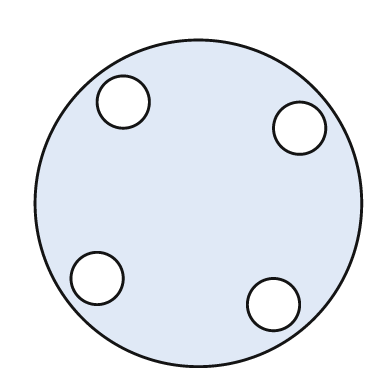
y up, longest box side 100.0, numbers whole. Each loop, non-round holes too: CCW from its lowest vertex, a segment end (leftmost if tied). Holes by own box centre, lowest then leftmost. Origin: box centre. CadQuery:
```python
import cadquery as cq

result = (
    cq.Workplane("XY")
    .moveTo(0.0, 0.0)
    .circle(50.0)
    .moveTo(23.0, -31.0)
    .circle(8.0)
    .moveTo(-31.0, -23.0)
    .circle(8.0)
    .moveTo(31.0, 23.0)
    .circle(8.0)
    .moveTo(-23.0, 31.0)
    .circle(8.0)
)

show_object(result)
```